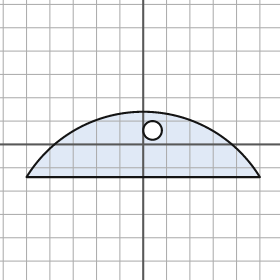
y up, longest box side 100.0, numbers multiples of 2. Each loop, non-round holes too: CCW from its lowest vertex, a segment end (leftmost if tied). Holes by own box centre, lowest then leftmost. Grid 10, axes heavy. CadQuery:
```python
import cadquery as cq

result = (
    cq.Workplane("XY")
    .moveTo(-50.0, -14.0)
    .lineTo(50.0, -14.0)
    .threePointArc((0.0, 14.0), (-50.0, -14.0))
    .close()
    .moveTo(4.0, 6.0)
    .circle(4.0)
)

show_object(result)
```